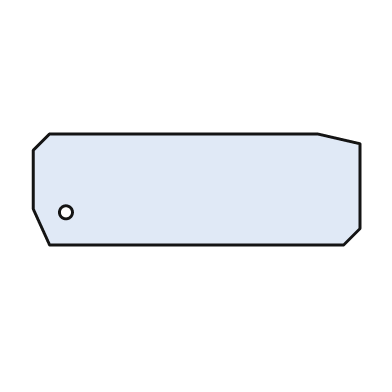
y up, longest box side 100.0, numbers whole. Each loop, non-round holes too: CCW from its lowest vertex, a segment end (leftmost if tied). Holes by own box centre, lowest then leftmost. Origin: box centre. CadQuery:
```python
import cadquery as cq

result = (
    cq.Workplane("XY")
    .moveTo(-45.0, -17.0)
    .lineTo(45.0, -17.0)
    .lineTo(50.0, -12.0)
    .lineTo(50.0, 14.0)
    .lineTo(37.0, 17.0)
    .lineTo(-45.0, 17.0)
    .lineTo(-50.0, 12.0)
    .lineTo(-50.0, -6.0)
    .close()
    .moveTo(-40.0, -7.0)
    .circle(2.0)
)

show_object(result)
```